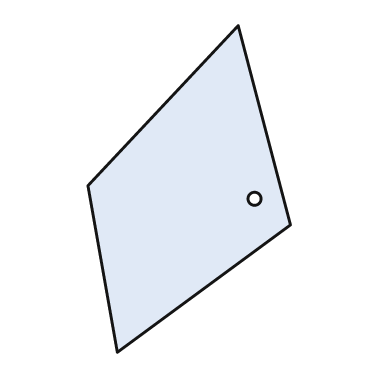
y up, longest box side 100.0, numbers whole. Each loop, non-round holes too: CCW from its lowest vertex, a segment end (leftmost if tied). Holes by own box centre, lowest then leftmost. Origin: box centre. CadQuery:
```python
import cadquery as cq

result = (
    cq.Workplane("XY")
    .moveTo(-22.0, -50.0)
    .lineTo(31.0, -11.0)
    .lineTo(15.0, 50.0)
    .lineTo(-31.0, 1.0)
    .close()
    .moveTo(20.0, -3.0)
    .circle(2.0)
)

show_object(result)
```